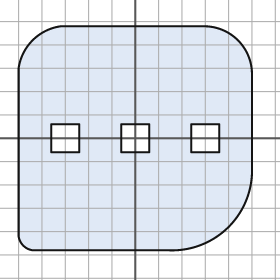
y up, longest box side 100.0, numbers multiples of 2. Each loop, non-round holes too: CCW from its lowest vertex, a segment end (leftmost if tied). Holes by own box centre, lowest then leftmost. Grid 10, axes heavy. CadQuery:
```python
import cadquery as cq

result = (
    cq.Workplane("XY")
    .moveTo(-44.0, -48.0)
    .lineTo(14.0, -48.0)
    .threePointArc((40.0, -38.0), (50.0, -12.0))
    .lineTo(50.0, 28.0)
    .threePointArc((44.0, 42.0), (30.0, 48.0))
    .lineTo(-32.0, 48.0)
    .threePointArc((-44.0, 42.0), (-50.0, 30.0))
    .lineTo(-50.0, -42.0)
    .threePointArc((-48.0, -46.0), (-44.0, -48.0))
    .close()
    .moveTo(-36.0, -6.0)
    .lineTo(-24.0, -6.0)
    .lineTo(-24.0, 6.0)
    .lineTo(-36.0, 6.0)
    .close()
    .moveTo(-6.0, -6.0)
    .lineTo(6.0, -6.0)
    .lineTo(6.0, 6.0)
    .lineTo(-6.0, 6.0)
    .close()
    .moveTo(24.0, -6.0)
    .lineTo(36.0, -6.0)
    .lineTo(36.0, 6.0)
    .lineTo(24.0, 6.0)
    .close()
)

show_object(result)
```